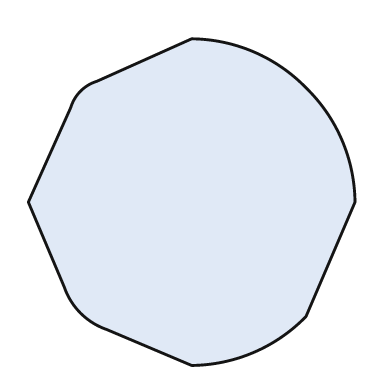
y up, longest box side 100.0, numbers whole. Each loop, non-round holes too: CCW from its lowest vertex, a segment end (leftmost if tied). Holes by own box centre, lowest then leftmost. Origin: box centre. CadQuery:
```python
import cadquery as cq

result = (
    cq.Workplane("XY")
    .moveTo(0.0, -50.0)
    .threePointArc((19.0, -46.0), (35.0, -35.0))
    .lineTo(50.0, 0.0)
    .threePointArc((46.0, 19.0), (35.0, 35.0))
    .threePointArc((19.0, 46.0), (0.0, 50.0))
    .lineTo(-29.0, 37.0)
    .threePointArc((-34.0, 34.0), (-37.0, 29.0))
    .lineTo(-50.0, 0.0)
    .lineTo(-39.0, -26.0)
    .threePointArc((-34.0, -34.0), (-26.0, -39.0))
    .close()
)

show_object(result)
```